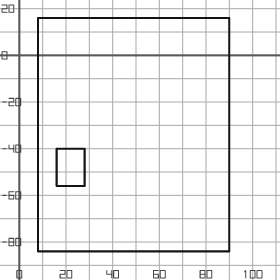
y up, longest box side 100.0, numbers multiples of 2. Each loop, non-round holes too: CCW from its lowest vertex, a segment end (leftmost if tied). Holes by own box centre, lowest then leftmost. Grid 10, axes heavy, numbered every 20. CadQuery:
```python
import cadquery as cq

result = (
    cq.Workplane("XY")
    .moveTo(8.0, -84.0)
    .lineTo(90.0, -84.0)
    .lineTo(90.0, 16.0)
    .lineTo(8.0, 16.0)
    .close()
    .moveTo(16.0, -56.0)
    .lineTo(28.0, -56.0)
    .lineTo(28.0, -40.0)
    .lineTo(16.0, -40.0)
    .close()
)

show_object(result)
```